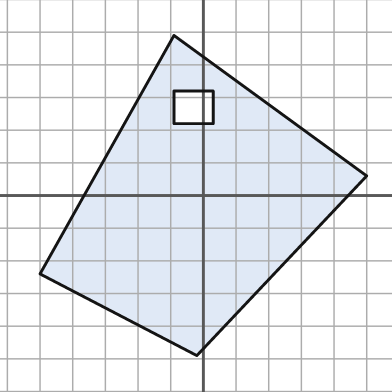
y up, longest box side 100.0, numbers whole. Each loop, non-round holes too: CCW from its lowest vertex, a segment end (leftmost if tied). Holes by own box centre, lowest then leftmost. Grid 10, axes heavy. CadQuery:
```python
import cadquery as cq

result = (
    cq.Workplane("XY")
    .moveTo(-2.0, -49.0)
    .lineTo(50.0, 6.0)
    .lineTo(-9.0, 49.0)
    .lineTo(-50.0, -24.0)
    .close()
    .moveTo(-9.0, 22.0)
    .lineTo(3.0, 22.0)
    .lineTo(3.0, 32.0)
    .lineTo(-9.0, 32.0)
    .close()
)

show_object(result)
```